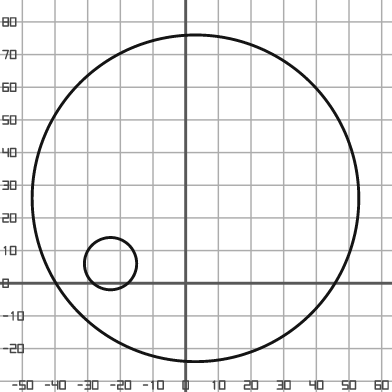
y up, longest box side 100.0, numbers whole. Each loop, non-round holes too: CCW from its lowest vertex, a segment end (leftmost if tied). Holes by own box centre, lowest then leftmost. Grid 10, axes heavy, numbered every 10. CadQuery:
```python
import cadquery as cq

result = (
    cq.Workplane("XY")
    .moveTo(3.0, 26.0)
    .circle(50.0)
    .moveTo(-23.0, 6.0)
    .circle(8.0)
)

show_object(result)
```